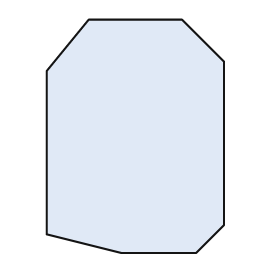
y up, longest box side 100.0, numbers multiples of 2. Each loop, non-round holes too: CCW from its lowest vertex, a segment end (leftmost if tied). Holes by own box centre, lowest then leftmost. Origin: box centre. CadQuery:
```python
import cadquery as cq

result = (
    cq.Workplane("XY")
    .moveTo(-6.0, -50.0)
    .lineTo(26.0, -50.0)
    .lineTo(38.0, -38.0)
    .lineTo(38.0, 32.0)
    .lineTo(20.0, 50.0)
    .lineTo(-20.0, 50.0)
    .lineTo(-38.0, 28.0)
    .lineTo(-38.0, -42.0)
    .close()
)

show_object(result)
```